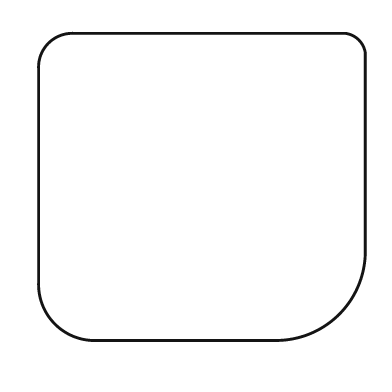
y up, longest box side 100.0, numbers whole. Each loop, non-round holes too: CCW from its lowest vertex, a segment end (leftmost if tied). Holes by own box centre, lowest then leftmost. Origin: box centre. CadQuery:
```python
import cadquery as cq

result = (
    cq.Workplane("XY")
    .moveTo(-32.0, -47.0)
    .lineTo(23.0, -47.0)
    .threePointArc((42.0, -39.0), (50.0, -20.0))
    .lineTo(50.0, 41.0)
    .threePointArc((48.0, 45.0), (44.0, 47.0))
    .lineTo(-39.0, 47.0)
    .threePointArc((-47.0, 44.0), (-50.0, 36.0))
    .lineTo(-50.0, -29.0)
    .threePointArc((-45.0, -42.0), (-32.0, -47.0))
    .close()
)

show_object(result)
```